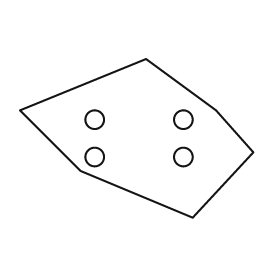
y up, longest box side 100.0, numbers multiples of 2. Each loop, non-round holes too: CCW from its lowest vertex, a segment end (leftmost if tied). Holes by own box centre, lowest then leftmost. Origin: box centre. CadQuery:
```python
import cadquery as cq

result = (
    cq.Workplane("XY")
    .moveTo(24.0, -34.0)
    .lineTo(50.0, -6.0)
    .lineTo(34.0, 12.0)
    .lineTo(4.0, 34.0)
    .lineTo(-50.0, 12.0)
    .lineTo(-24.0, -14.0)
    .close()
    .moveTo(-18.0, -8.0)
    .circle(4.0)
    .moveTo(20.0, -8.0)
    .circle(4.0)
    .moveTo(-18.0, 8.0)
    .circle(4.0)
    .moveTo(20.0, 8.0)
    .circle(4.0)
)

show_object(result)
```